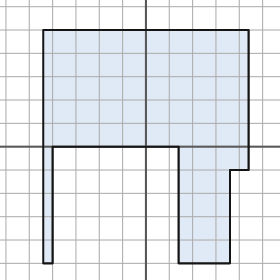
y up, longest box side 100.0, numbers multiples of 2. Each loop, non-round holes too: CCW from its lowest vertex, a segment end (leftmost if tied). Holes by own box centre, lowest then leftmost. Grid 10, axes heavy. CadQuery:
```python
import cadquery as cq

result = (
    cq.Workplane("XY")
    .moveTo(-44.0, -50.0)
    .lineTo(-40.0, -50.0)
    .lineTo(-40.0, 0.0)
    .lineTo(14.0, 0.0)
    .lineTo(14.0, -50.0)
    .lineTo(36.0, -50.0)
    .lineTo(36.0, -10.0)
    .lineTo(44.0, -10.0)
    .lineTo(44.0, 50.0)
    .lineTo(-44.0, 50.0)
    .close()
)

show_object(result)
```